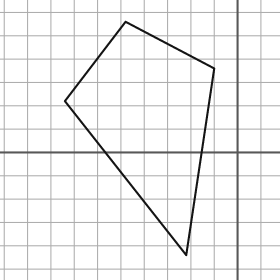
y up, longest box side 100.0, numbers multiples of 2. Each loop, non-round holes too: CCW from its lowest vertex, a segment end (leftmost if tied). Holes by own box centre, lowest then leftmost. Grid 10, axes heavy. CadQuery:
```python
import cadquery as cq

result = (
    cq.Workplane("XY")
    .moveTo(-22.0, -44.0)
    .lineTo(-10.0, 36.0)
    .lineTo(-48.0, 56.0)
    .lineTo(-74.0, 22.0)
    .close()
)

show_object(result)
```